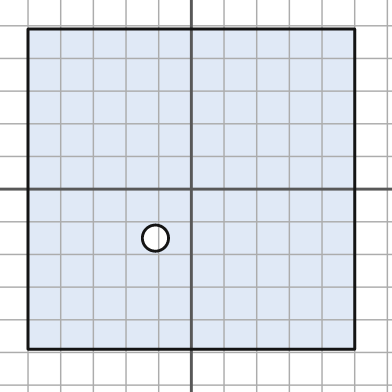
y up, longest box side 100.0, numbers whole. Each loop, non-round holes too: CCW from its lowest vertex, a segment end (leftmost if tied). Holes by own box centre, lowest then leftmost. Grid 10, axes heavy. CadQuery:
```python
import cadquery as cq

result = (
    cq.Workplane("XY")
    .moveTo(-50.0, -49.0)
    .lineTo(50.0, -49.0)
    .lineTo(50.0, 49.0)
    .lineTo(-50.0, 49.0)
    .close()
    .moveTo(-11.0, -15.0)
    .circle(4.0)
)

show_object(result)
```